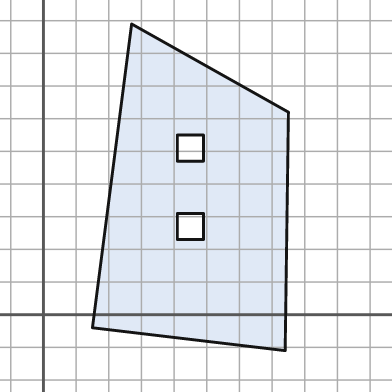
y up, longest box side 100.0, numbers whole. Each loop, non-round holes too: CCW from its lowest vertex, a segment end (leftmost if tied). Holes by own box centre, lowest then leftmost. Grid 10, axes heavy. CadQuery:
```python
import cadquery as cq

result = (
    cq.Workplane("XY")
    .moveTo(74.0, -11.0)
    .lineTo(75.0, 62.0)
    .lineTo(27.0, 89.0)
    .lineTo(15.0, -4.0)
    .close()
    .moveTo(41.0, 23.0)
    .lineTo(49.0, 23.0)
    .lineTo(49.0, 31.0)
    .lineTo(41.0, 31.0)
    .close()
    .moveTo(41.0, 47.0)
    .lineTo(49.0, 47.0)
    .lineTo(49.0, 55.0)
    .lineTo(41.0, 55.0)
    .close()
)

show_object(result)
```